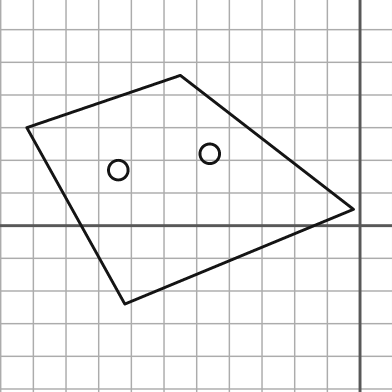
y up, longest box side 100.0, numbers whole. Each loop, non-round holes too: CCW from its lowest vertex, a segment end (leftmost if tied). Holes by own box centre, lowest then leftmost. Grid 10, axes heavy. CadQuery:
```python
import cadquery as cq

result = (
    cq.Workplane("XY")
    .moveTo(-72.0, -24.0)
    .lineTo(-2.0, 5.0)
    .lineTo(-55.0, 46.0)
    .lineTo(-102.0, 30.0)
    .close()
    .moveTo(-74.0, 17.0)
    .circle(3.0)
    .moveTo(-46.0, 22.0)
    .circle(3.0)
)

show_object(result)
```